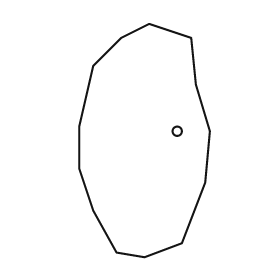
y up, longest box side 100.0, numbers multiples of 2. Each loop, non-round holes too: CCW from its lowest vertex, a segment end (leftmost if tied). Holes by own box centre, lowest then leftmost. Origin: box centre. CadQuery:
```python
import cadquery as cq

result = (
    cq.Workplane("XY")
    .moveTo(0.0, -50.0)
    .lineTo(16.0, -44.0)
    .lineTo(26.0, -18.0)
    .lineTo(28.0, 4.0)
    .lineTo(22.0, 24.0)
    .lineTo(20.0, 44.0)
    .lineTo(2.0, 50.0)
    .lineTo(-10.0, 44.0)
    .lineTo(-22.0, 32.0)
    .lineTo(-28.0, 6.0)
    .lineTo(-28.0, -12.0)
    .lineTo(-22.0, -30.0)
    .lineTo(-12.0, -48.0)
    .close()
    .moveTo(14.0, 4.0)
    .circle(2.0)
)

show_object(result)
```